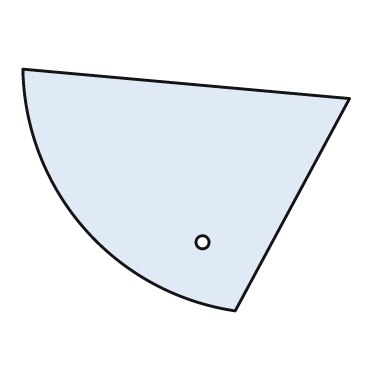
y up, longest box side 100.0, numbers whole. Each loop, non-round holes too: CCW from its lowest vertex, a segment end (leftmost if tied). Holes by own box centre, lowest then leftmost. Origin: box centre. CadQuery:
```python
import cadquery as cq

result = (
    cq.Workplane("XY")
    .moveTo(15.0, -37.0)
    .lineTo(50.0, 28.0)
    .lineTo(-50.0, 37.0)
    .threePointArc((-31.0, -12.0), (15.0, -37.0))
    .close()
    .moveTo(5.0, -16.0)
    .circle(2.0)
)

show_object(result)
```